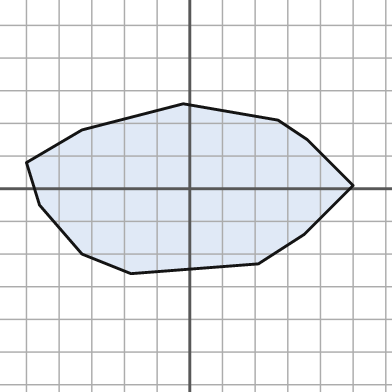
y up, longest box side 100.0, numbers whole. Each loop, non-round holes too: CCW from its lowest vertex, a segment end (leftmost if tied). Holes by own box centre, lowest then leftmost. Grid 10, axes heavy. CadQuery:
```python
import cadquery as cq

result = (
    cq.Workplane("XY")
    .moveTo(-18.0, -26.0)
    .lineTo(21.0, -23.0)
    .lineTo(35.0, -14.0)
    .lineTo(50.0, 1.0)
    .lineTo(36.0, 15.0)
    .lineTo(27.0, 21.0)
    .lineTo(-2.0, 26.0)
    .lineTo(-33.0, 18.0)
    .lineTo(-50.0, 8.0)
    .lineTo(-46.0, -5.0)
    .lineTo(-33.0, -20.0)
    .close()
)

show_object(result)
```